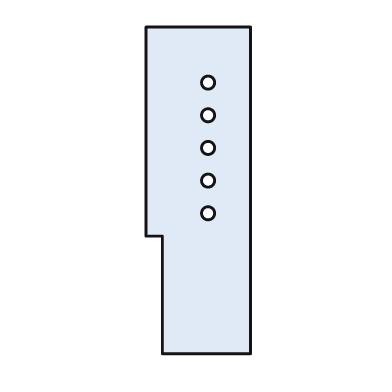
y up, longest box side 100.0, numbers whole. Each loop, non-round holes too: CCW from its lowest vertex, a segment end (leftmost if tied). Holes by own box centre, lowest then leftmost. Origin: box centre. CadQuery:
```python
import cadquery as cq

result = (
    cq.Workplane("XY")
    .moveTo(-11.0, -50.0)
    .lineTo(16.0, -50.0)
    .lineTo(16.0, 50.0)
    .lineTo(-16.0, 50.0)
    .lineTo(-16.0, -14.0)
    .lineTo(-11.0, -14.0)
    .close()
    .moveTo(3.0, -7.0)
    .circle(2.0)
    .moveTo(3.0, 3.0)
    .circle(2.0)
    .moveTo(3.0, 13.0)
    .circle(2.0)
    .moveTo(3.0, 23.0)
    .circle(2.0)
    .moveTo(3.0, 33.0)
    .circle(2.0)
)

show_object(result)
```